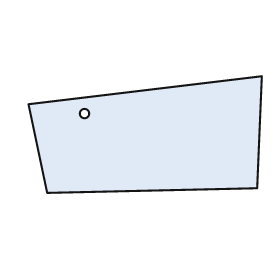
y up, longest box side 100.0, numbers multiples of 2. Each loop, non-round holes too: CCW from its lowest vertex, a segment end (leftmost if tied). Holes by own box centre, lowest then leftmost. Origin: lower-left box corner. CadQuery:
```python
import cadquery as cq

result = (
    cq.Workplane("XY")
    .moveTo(8.0, 0.0)
    .lineTo(98.0, 2.0)
    .lineTo(100.0, 50.0)
    .lineTo(0.0, 38.0)
    .close()
    .moveTo(24.0, 34.0)
    .circle(2.0)
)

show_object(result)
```